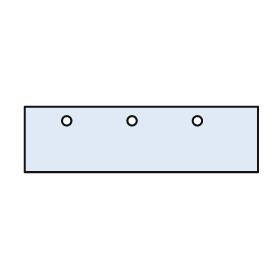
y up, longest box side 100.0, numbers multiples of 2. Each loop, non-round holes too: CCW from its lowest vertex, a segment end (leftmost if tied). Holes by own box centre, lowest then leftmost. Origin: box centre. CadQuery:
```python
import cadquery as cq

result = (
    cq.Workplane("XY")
    .moveTo(-50.0, -14.0)
    .lineTo(50.0, -14.0)
    .lineTo(50.0, 14.0)
    .lineTo(-50.0, 14.0)
    .close()
    .moveTo(-32.0, 8.0)
    .circle(2.0)
    .moveTo(-4.0, 8.0)
    .circle(2.0)
    .moveTo(24.0, 8.0)
    .circle(2.0)
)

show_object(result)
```